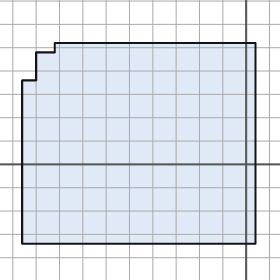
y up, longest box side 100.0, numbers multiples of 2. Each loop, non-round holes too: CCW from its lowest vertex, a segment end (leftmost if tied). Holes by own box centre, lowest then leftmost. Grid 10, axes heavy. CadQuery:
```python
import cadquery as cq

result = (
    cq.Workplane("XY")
    .moveTo(-96.0, -34.0)
    .lineTo(4.0, -34.0)
    .lineTo(4.0, 52.0)
    .lineTo(-82.0, 52.0)
    .lineTo(-82.0, 48.0)
    .lineTo(-90.0, 48.0)
    .lineTo(-90.0, 36.0)
    .lineTo(-96.0, 36.0)
    .close()
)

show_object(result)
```